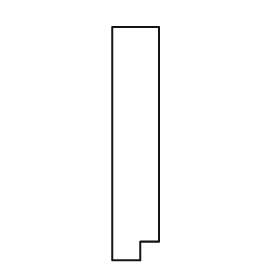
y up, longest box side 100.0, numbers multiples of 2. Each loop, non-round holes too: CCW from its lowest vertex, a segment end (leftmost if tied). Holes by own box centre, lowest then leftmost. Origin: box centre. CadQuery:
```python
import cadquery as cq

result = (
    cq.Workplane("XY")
    .moveTo(-10.0, -50.0)
    .lineTo(2.0, -50.0)
    .lineTo(2.0, -42.0)
    .lineTo(10.0, -42.0)
    .lineTo(10.0, 50.0)
    .lineTo(-10.0, 50.0)
    .close()
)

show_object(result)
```